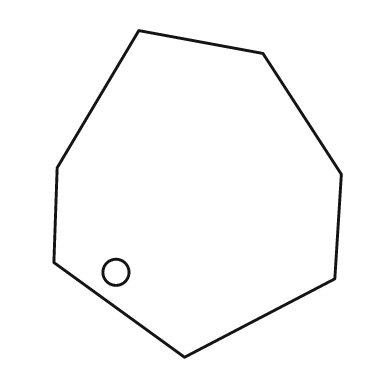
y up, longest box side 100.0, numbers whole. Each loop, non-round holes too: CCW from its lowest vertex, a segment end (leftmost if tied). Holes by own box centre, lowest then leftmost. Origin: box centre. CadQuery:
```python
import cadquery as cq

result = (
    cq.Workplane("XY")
    .moveTo(-4.0, -50.0)
    .lineTo(42.0, -26.0)
    .lineTo(44.0, 6.0)
    .lineTo(20.0, 43.0)
    .lineTo(-18.0, 50.0)
    .lineTo(-43.0, 8.0)
    .lineTo(-44.0, -21.0)
    .close()
    .moveTo(-25.0, -24.0)
    .circle(4.0)
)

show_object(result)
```